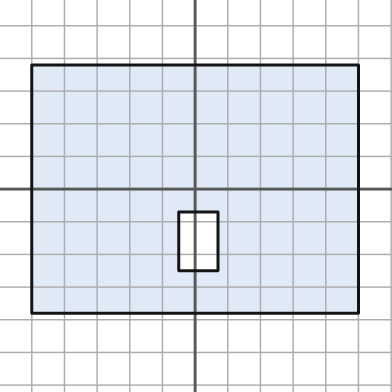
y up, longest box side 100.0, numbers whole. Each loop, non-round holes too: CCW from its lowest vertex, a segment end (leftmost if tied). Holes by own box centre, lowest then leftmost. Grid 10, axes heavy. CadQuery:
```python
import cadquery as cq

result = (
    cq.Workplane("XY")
    .moveTo(-50.0, -38.0)
    .lineTo(50.0, -38.0)
    .lineTo(50.0, 38.0)
    .lineTo(-50.0, 38.0)
    .close()
    .moveTo(-5.0, -25.0)
    .lineTo(7.0, -25.0)
    .lineTo(7.0, -7.0)
    .lineTo(-5.0, -7.0)
    .close()
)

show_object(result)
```